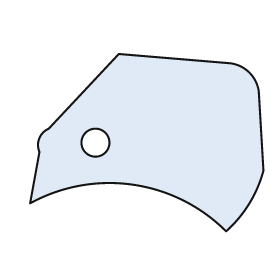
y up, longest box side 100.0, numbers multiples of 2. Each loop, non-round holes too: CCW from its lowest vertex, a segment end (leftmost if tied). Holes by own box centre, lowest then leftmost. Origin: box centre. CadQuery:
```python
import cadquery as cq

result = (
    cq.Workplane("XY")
    .moveTo(34.0, -38.0)
    .threePointArc((44.0, -26.0), (50.0, -12.0))
    .lineTo(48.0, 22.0)
    .threePointArc((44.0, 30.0), (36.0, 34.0))
    .lineTo(-12.0, 38.0)
    .lineTo(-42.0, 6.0)
    .threePointArc((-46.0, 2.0), (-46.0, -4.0))
    .lineTo(-50.0, -26.0)
    .threePointArc((-6.0, -18.0), (34.0, -38.0))
    .close()
    .moveTo(-22.0, 0.0)
    .circle(6.0)
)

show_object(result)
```